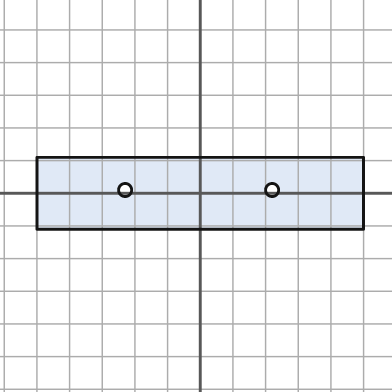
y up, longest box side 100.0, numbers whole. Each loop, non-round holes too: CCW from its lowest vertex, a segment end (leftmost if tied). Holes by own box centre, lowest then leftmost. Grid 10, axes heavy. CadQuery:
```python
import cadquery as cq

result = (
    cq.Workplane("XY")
    .moveTo(-50.0, -11.0)
    .lineTo(50.0, -11.0)
    .lineTo(50.0, 11.0)
    .lineTo(-50.0, 11.0)
    .close()
    .moveTo(-23.0, 1.0)
    .circle(2.0)
    .moveTo(22.0, 1.0)
    .circle(2.0)
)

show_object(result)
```